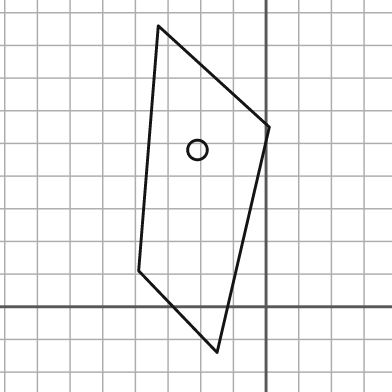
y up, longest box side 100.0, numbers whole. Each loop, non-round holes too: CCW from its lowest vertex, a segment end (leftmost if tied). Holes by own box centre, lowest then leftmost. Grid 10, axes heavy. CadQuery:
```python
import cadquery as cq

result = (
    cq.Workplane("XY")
    .moveTo(-15.0, -14.0)
    .lineTo(1.0, 55.0)
    .lineTo(-33.0, 86.0)
    .lineTo(-39.0, 11.0)
    .close()
    .moveTo(-21.0, 48.0)
    .circle(3.0)
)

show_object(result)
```